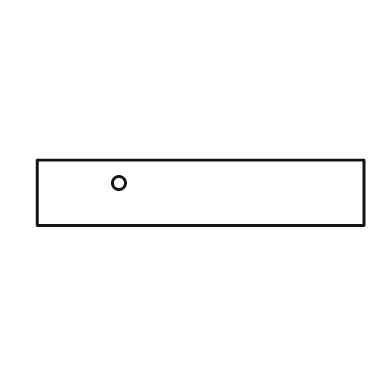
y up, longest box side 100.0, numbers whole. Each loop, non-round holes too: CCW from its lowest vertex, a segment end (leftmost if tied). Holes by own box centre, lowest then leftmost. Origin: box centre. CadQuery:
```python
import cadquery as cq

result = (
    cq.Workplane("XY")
    .moveTo(-50.0, -10.0)
    .lineTo(50.0, -10.0)
    .lineTo(50.0, 10.0)
    .lineTo(-50.0, 10.0)
    .close()
    .moveTo(-25.0, 3.0)
    .circle(2.0)
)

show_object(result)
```